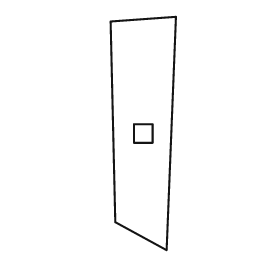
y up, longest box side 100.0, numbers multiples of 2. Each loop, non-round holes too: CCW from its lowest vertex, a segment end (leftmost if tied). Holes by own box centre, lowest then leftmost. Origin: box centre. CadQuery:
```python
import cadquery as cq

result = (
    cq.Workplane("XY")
    .moveTo(10.0, -50.0)
    .lineTo(14.0, 50.0)
    .lineTo(-14.0, 48.0)
    .lineTo(-12.0, -38.0)
    .close()
    .moveTo(-4.0, -4.0)
    .lineTo(4.0, -4.0)
    .lineTo(4.0, 4.0)
    .lineTo(-4.0, 4.0)
    .close()
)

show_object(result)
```